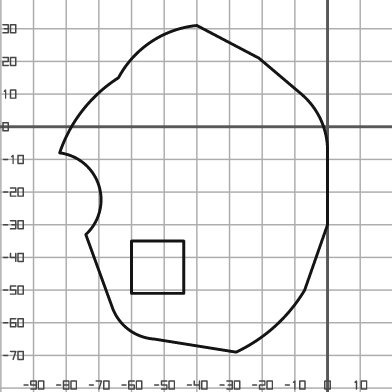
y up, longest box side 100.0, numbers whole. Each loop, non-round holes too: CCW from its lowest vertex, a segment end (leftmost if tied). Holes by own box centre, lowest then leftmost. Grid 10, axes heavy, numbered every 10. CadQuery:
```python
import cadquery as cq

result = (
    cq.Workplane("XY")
    .moveTo(-28.0, -69.0)
    .threePointArc((-16.0, -61.0), (-7.0, -50.0))
    .lineTo(0.0, -30.0)
    .lineTo(0.0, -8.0)
    .threePointArc((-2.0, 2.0), (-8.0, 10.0))
    .lineTo(-21.0, 21.0)
    .lineTo(-40.0, 31.0)
    .threePointArc((-54.0, 26.0), (-64.0, 15.0))
    .threePointArc((-75.0, 5.0), (-82.0, -8.0))
    .threePointArc((-70.0, -18.0), (-74.0, -33.0))
    .lineTo(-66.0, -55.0)
    .threePointArc((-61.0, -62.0), (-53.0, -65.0))
    .close()
    .moveTo(-60.0, -51.0)
    .lineTo(-44.0, -51.0)
    .lineTo(-44.0, -35.0)
    .lineTo(-60.0, -35.0)
    .close()
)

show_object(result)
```